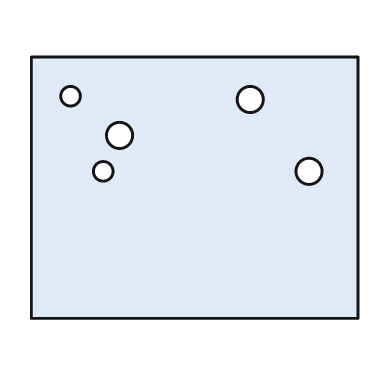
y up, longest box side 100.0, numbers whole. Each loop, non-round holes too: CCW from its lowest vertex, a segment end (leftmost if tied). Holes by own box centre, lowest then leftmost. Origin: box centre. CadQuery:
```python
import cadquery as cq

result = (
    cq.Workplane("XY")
    .moveTo(-50.0, -40.0)
    .lineTo(50.0, -40.0)
    .lineTo(50.0, 40.0)
    .lineTo(-50.0, 40.0)
    .close()
    .moveTo(-28.0, 5.0)
    .circle(3.0)
    .moveTo(35.0, 5.0)
    .circle(4.0)
    .moveTo(-23.0, 16.0)
    .circle(4.0)
    .moveTo(17.0, 27.0)
    .circle(4.0)
    .moveTo(-38.0, 28.0)
    .circle(3.0)
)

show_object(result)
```